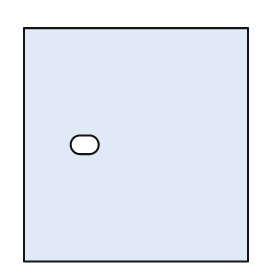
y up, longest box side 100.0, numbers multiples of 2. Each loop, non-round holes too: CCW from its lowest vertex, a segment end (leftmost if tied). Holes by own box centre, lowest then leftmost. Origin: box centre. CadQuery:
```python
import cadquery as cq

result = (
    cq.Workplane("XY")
    .moveTo(-48.0, -50.0)
    .lineTo(48.0, -50.0)
    .lineTo(48.0, 50.0)
    .lineTo(-48.0, 50.0)
    .close()
    .moveTo(-24.0, -4.0)
    .lineTo(-20.0, -4.0)
    .threePointArc((-16.0, 0.0), (-20.0, 4.0))
    .lineTo(-24.0, 4.0)
    .threePointArc((-28.0, 0.0), (-24.0, -4.0))
    .close()
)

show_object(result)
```